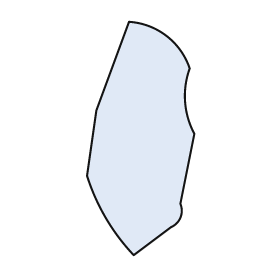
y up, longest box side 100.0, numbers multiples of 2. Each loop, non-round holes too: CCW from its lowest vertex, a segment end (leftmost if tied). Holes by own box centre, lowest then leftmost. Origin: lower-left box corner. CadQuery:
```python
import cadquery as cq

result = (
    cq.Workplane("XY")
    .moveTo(20.0, 0.0)
    .lineTo(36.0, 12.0)
    .threePointArc((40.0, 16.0), (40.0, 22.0))
    .lineTo(46.0, 52.0)
    .threePointArc((42.0, 66.0), (44.0, 80.0))
    .threePointArc((34.0, 94.0), (18.0, 100.0))
    .lineTo(4.0, 62.0)
    .lineTo(0.0, 34.0)
    .threePointArc((8.0, 16.0), (20.0, 0.0))
    .close()
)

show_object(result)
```